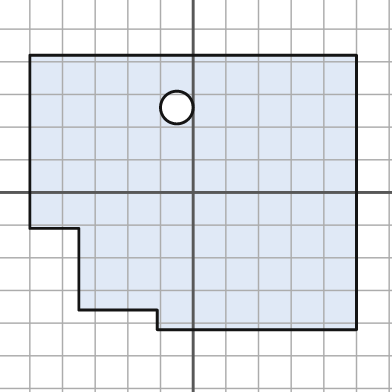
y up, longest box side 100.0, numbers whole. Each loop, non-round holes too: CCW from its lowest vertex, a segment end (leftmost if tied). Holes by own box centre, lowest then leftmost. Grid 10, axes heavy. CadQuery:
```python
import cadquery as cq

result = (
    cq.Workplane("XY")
    .moveTo(-11.0, -42.0)
    .lineTo(50.0, -42.0)
    .lineTo(50.0, 42.0)
    .lineTo(-50.0, 42.0)
    .lineTo(-50.0, -11.0)
    .lineTo(-35.0, -11.0)
    .lineTo(-35.0, -36.0)
    .lineTo(-11.0, -36.0)
    .close()
    .moveTo(-5.0, 26.0)
    .circle(5.0)
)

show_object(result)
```